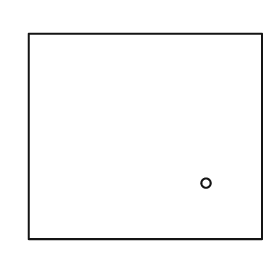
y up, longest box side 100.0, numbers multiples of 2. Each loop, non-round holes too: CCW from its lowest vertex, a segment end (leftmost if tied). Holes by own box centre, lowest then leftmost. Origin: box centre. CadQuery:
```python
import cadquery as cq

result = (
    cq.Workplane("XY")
    .moveTo(-50.0, -44.0)
    .lineTo(50.0, -44.0)
    .lineTo(50.0, 44.0)
    .lineTo(-50.0, 44.0)
    .close()
    .moveTo(26.0, -20.0)
    .circle(2.0)
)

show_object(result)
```